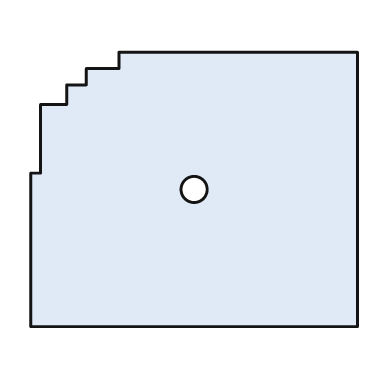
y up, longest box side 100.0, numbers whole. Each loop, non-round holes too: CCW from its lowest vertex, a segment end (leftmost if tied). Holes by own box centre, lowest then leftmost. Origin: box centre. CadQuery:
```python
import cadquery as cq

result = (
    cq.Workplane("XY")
    .moveTo(-50.0, -42.0)
    .lineTo(50.0, -42.0)
    .lineTo(50.0, 42.0)
    .lineTo(-23.0, 42.0)
    .lineTo(-23.0, 37.0)
    .lineTo(-33.0, 37.0)
    .lineTo(-33.0, 32.0)
    .lineTo(-39.0, 32.0)
    .lineTo(-39.0, 26.0)
    .lineTo(-47.0, 26.0)
    .lineTo(-47.0, 5.0)
    .lineTo(-50.0, 5.0)
    .close()
    .moveTo(0.0, 0.0)
    .circle(4.0)
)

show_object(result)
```